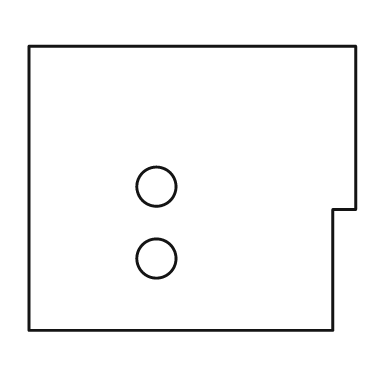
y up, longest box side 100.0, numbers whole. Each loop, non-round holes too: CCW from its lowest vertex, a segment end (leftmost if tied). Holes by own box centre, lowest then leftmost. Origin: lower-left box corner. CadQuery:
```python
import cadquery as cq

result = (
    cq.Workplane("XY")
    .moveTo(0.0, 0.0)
    .lineTo(93.0, 0.0)
    .lineTo(93.0, 37.0)
    .lineTo(100.0, 37.0)
    .lineTo(100.0, 87.0)
    .lineTo(0.0, 87.0)
    .close()
    .moveTo(39.0, 22.0)
    .circle(6.0)
    .moveTo(39.0, 44.0)
    .circle(6.0)
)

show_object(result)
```